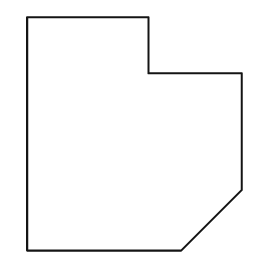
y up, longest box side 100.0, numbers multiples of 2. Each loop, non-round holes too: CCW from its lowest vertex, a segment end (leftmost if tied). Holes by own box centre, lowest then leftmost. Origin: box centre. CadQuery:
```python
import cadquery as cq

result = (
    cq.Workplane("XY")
    .moveTo(-46.0, -50.0)
    .lineTo(20.0, -50.0)
    .lineTo(46.0, -24.0)
    .lineTo(46.0, 26.0)
    .lineTo(6.0, 26.0)
    .lineTo(6.0, 50.0)
    .lineTo(-46.0, 50.0)
    .close()
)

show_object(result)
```